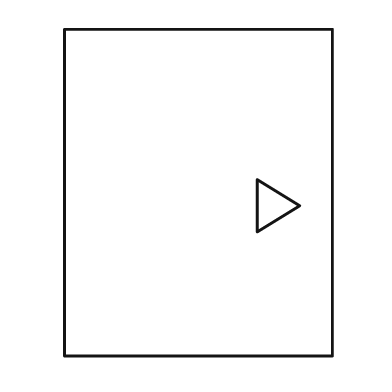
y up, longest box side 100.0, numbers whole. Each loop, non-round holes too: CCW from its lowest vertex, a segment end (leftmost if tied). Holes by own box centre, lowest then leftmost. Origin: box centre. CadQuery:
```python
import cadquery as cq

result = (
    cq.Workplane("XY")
    .moveTo(-41.0, -50.0)
    .lineTo(41.0, -50.0)
    .lineTo(41.0, 50.0)
    .lineTo(-41.0, 50.0)
    .close()
    .moveTo(18.0, -12.0)
    .lineTo(31.0, -4.0)
    .lineTo(18.0, 4.0)
    .close()
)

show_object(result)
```